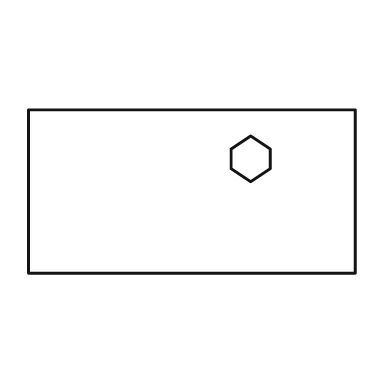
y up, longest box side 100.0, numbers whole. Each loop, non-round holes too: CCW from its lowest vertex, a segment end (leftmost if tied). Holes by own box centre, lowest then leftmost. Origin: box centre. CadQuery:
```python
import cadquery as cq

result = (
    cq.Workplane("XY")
    .moveTo(-50.0, -25.0)
    .lineTo(50.0, -25.0)
    .lineTo(50.0, 25.0)
    .lineTo(-50.0, 25.0)
    .close()
    .moveTo(18.0, 3.0)
    .lineTo(24.0, 7.0)
    .lineTo(24.0, 13.0)
    .lineTo(18.0, 17.0)
    .lineTo(12.0, 13.0)
    .lineTo(12.0, 7.0)
    .close()
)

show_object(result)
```